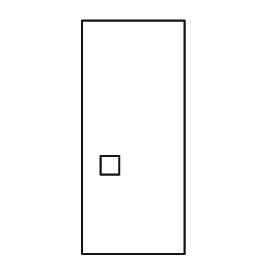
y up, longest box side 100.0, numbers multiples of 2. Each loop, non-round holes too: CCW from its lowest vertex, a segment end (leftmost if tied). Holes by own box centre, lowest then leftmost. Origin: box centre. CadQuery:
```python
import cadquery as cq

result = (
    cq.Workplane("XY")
    .moveTo(-22.0, -50.0)
    .lineTo(22.0, -50.0)
    .lineTo(22.0, 50.0)
    .lineTo(-22.0, 50.0)
    .close()
    .moveTo(-14.0, -16.0)
    .lineTo(-6.0, -16.0)
    .lineTo(-6.0, -8.0)
    .lineTo(-14.0, -8.0)
    .close()
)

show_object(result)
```